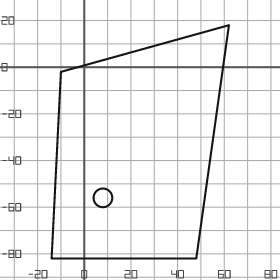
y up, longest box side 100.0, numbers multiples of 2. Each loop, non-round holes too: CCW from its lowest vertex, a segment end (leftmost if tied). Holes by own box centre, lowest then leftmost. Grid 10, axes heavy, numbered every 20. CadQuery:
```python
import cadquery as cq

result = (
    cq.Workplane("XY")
    .moveTo(-14.0, -82.0)
    .lineTo(48.0, -82.0)
    .lineTo(62.0, 18.0)
    .lineTo(-10.0, -2.0)
    .close()
    .moveTo(8.0, -56.0)
    .circle(4.0)
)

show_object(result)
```